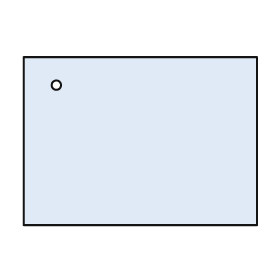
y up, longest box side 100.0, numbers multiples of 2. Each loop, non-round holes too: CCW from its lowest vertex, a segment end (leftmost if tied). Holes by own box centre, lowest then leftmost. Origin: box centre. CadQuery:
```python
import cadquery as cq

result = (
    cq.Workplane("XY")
    .moveTo(-50.0, -36.0)
    .lineTo(50.0, -36.0)
    .lineTo(50.0, 36.0)
    .lineTo(-50.0, 36.0)
    .close()
    .moveTo(-36.0, 24.0)
    .circle(2.0)
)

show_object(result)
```